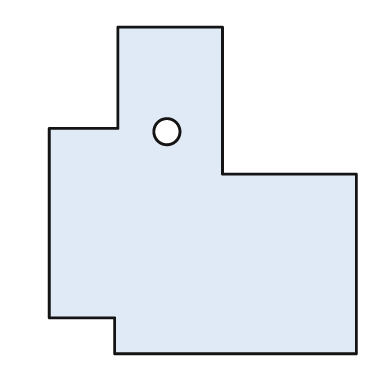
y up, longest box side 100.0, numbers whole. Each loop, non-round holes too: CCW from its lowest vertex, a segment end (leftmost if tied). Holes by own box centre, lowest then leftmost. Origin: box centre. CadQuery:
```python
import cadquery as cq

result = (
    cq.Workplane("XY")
    .moveTo(-27.0, -50.0)
    .lineTo(47.0, -50.0)
    .lineTo(47.0, 5.0)
    .lineTo(6.0, 5.0)
    .lineTo(6.0, 50.0)
    .lineTo(-26.0, 50.0)
    .lineTo(-26.0, 19.0)
    .lineTo(-47.0, 19.0)
    .lineTo(-47.0, -39.0)
    .lineTo(-27.0, -39.0)
    .close()
    .moveTo(-11.0, 18.0)
    .circle(4.0)
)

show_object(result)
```